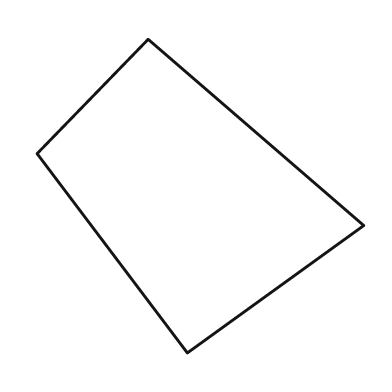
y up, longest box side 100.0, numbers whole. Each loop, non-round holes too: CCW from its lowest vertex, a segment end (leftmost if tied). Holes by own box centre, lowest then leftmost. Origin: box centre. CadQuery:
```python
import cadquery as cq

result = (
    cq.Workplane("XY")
    .moveTo(-4.0, -48.0)
    .lineTo(50.0, -9.0)
    .lineTo(-16.0, 48.0)
    .lineTo(-50.0, 13.0)
    .close()
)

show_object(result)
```